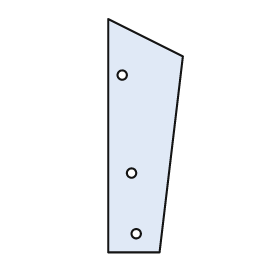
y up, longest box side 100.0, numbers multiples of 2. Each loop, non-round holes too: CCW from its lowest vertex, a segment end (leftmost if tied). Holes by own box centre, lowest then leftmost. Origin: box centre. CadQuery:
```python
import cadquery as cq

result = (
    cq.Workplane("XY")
    .moveTo(-16.0, -50.0)
    .lineTo(6.0, -50.0)
    .lineTo(16.0, 34.0)
    .lineTo(-16.0, 50.0)
    .close()
    .moveTo(-4.0, -42.0)
    .circle(2.0)
    .moveTo(-6.0, -16.0)
    .circle(2.0)
    .moveTo(-10.0, 26.0)
    .circle(2.0)
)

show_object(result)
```